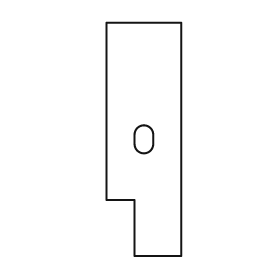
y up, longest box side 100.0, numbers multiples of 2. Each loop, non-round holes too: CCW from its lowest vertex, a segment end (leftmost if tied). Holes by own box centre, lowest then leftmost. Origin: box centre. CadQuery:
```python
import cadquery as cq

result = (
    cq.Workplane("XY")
    .moveTo(-4.0, -50.0)
    .lineTo(16.0, -50.0)
    .lineTo(16.0, 50.0)
    .lineTo(-16.0, 50.0)
    .lineTo(-16.0, -26.0)
    .lineTo(-4.0, -26.0)
    .close()
    .moveTo(-4.0, -2.0)
    .threePointArc((0.0, -6.0), (4.0, -2.0))
    .lineTo(4.0, 2.0)
    .threePointArc((0.0, 6.0), (-4.0, 2.0))
    .close()
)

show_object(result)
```